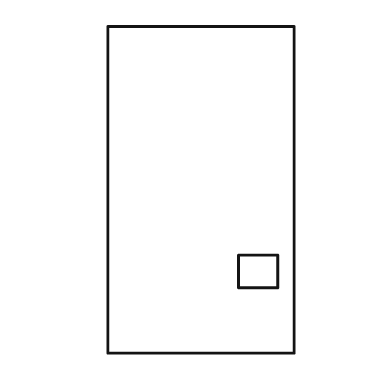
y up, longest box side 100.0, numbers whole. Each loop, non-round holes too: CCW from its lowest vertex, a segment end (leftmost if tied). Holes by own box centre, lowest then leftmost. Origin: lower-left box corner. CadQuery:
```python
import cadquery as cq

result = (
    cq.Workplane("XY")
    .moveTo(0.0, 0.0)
    .lineTo(57.0, 0.0)
    .lineTo(57.0, 100.0)
    .lineTo(0.0, 100.0)
    .close()
    .moveTo(40.0, 20.0)
    .lineTo(52.0, 20.0)
    .lineTo(52.0, 30.0)
    .lineTo(40.0, 30.0)
    .close()
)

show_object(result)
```